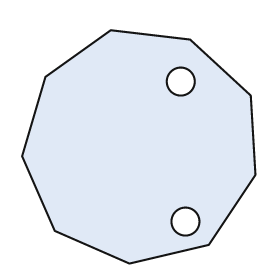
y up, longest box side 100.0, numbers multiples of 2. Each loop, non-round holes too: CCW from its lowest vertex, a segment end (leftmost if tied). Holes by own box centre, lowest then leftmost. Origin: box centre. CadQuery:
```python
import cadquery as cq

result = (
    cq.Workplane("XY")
    .moveTo(-4.0, -50.0)
    .lineTo(30.0, -42.0)
    .lineTo(50.0, -12.0)
    .lineTo(48.0, 22.0)
    .lineTo(22.0, 46.0)
    .lineTo(-12.0, 50.0)
    .lineTo(-40.0, 30.0)
    .lineTo(-50.0, -4.0)
    .lineTo(-36.0, -36.0)
    .close()
    .moveTo(20.0, -32.0)
    .circle(6.0)
    .moveTo(18.0, 28.0)
    .circle(6.0)
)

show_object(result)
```